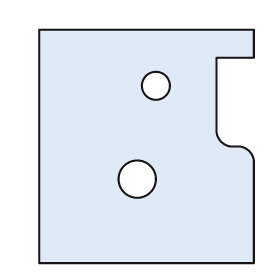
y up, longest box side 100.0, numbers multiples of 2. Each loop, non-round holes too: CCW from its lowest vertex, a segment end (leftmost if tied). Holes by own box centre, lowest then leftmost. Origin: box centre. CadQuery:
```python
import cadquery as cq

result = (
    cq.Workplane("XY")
    .moveTo(-46.0, -50.0)
    .lineTo(46.0, -50.0)
    .lineTo(46.0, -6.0)
    .threePointArc((44.0, -2.0), (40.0, 0.0))
    .lineTo(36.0, 0.0)
    .threePointArc((32.0, 2.0), (30.0, 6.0))
    .lineTo(30.0, 38.0)
    .lineTo(46.0, 38.0)
    .lineTo(46.0, 50.0)
    .lineTo(-46.0, 50.0)
    .close()
    .moveTo(-4.0, -14.0)
    .circle(8.0)
    .moveTo(4.0, 26.0)
    .circle(6.0)
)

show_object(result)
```